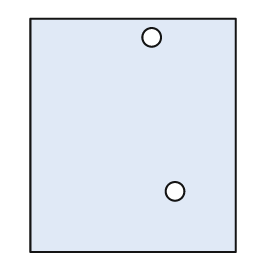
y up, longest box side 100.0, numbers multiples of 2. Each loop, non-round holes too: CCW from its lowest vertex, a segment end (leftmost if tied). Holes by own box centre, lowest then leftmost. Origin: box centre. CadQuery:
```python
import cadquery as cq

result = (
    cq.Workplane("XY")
    .moveTo(-44.0, -50.0)
    .lineTo(44.0, -50.0)
    .lineTo(44.0, 50.0)
    .lineTo(-44.0, 50.0)
    .close()
    .moveTo(18.0, -24.0)
    .circle(4.0)
    .moveTo(8.0, 42.0)
    .circle(4.0)
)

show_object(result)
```